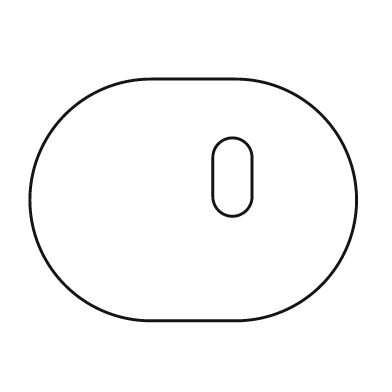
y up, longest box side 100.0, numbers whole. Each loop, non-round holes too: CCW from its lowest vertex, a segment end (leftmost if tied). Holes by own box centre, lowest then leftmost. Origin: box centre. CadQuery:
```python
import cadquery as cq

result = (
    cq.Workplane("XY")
    .moveTo(-13.0, -37.0)
    .lineTo(13.0, -37.0)
    .threePointArc((50.0, 0.0), (13.0, 37.0))
    .lineTo(-13.0, 37.0)
    .threePointArc((-50.0, 0.0), (-13.0, -37.0))
    .close()
    .moveTo(6.0, 1.0)
    .threePointArc((12.0, -5.0), (18.0, 1.0))
    .lineTo(18.0, 13.0)
    .threePointArc((12.0, 19.0), (6.0, 13.0))
    .close()
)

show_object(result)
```